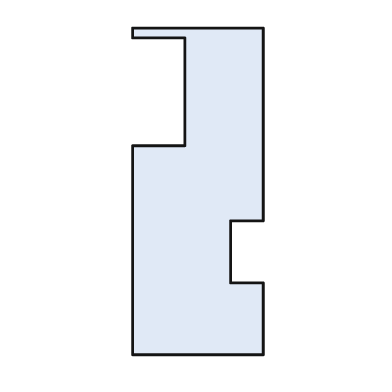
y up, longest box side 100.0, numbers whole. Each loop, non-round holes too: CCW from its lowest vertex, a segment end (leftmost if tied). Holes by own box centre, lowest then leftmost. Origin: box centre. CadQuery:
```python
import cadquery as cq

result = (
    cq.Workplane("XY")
    .moveTo(-20.0, -50.0)
    .lineTo(20.0, -50.0)
    .lineTo(20.0, -28.0)
    .lineTo(10.0, -28.0)
    .lineTo(10.0, -9.0)
    .lineTo(20.0, -9.0)
    .lineTo(20.0, 50.0)
    .lineTo(-20.0, 50.0)
    .lineTo(-20.0, 47.0)
    .lineTo(-4.0, 47.0)
    .lineTo(-4.0, 14.0)
    .lineTo(-20.0, 14.0)
    .close()
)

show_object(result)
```